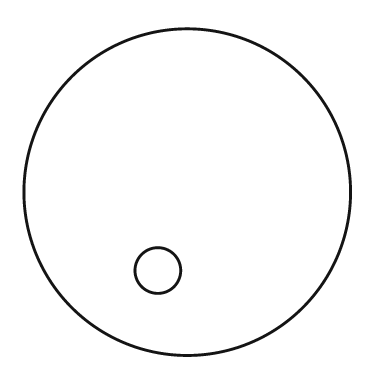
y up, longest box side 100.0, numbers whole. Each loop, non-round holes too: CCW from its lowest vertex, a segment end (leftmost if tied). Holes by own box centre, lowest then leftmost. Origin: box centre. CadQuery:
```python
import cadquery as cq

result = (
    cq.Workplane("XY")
    .moveTo(0.0, 0.0)
    .circle(50.0)
    .moveTo(-9.0, -24.0)
    .circle(7.0)
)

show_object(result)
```